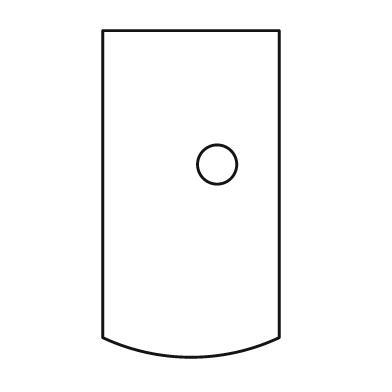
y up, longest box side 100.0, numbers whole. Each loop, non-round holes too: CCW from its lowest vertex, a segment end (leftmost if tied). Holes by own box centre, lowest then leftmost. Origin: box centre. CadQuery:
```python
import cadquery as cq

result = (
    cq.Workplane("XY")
    .moveTo(-27.0, -44.0)
    .threePointArc((0.0, -50.0), (27.0, -44.0))
    .lineTo(27.0, 50.0)
    .lineTo(-27.0, 50.0)
    .close()
    .moveTo(8.0, 9.0)
    .circle(6.0)
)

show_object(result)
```